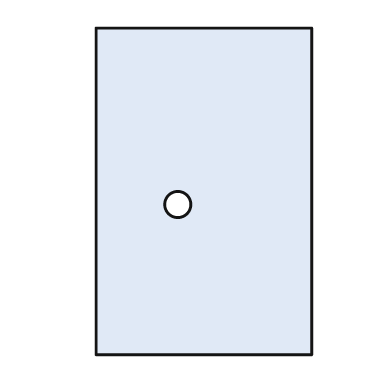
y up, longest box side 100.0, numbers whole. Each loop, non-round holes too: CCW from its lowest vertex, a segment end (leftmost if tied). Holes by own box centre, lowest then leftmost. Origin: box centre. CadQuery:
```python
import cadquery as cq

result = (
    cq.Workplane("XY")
    .moveTo(-33.0, -50.0)
    .lineTo(33.0, -50.0)
    .lineTo(33.0, 50.0)
    .lineTo(-33.0, 50.0)
    .close()
    .moveTo(-8.0, -4.0)
    .circle(4.0)
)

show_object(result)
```